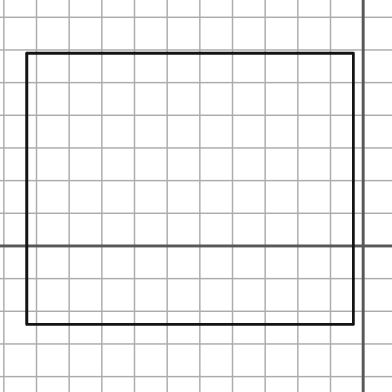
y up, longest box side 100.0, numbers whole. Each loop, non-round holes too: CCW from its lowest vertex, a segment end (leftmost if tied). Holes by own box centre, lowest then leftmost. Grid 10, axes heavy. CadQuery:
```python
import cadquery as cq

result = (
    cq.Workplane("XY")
    .moveTo(-103.0, -24.0)
    .lineTo(-3.0, -24.0)
    .lineTo(-3.0, 59.0)
    .lineTo(-103.0, 59.0)
    .close()
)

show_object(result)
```